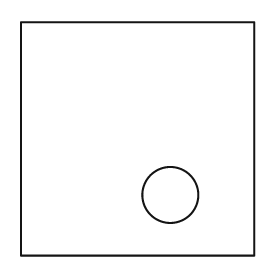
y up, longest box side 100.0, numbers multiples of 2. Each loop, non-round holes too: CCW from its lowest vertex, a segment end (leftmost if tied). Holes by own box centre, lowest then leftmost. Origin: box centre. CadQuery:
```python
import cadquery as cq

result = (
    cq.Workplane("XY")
    .moveTo(-50.0, -50.0)
    .lineTo(50.0, -50.0)
    .lineTo(50.0, 50.0)
    .lineTo(-50.0, 50.0)
    .close()
    .moveTo(14.0, -24.0)
    .circle(12.0)
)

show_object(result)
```